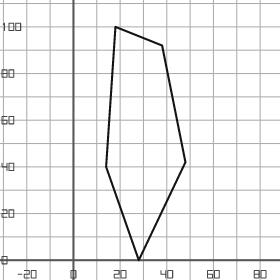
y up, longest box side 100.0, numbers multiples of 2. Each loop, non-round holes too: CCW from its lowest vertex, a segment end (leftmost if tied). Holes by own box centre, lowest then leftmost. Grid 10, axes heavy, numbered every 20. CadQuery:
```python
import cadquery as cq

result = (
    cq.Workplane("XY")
    .moveTo(28.0, 0.0)
    .lineTo(48.0, 42.0)
    .lineTo(38.0, 92.0)
    .lineTo(18.0, 100.0)
    .lineTo(14.0, 40.0)
    .close()
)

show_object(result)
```